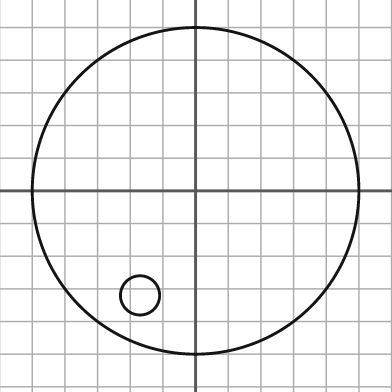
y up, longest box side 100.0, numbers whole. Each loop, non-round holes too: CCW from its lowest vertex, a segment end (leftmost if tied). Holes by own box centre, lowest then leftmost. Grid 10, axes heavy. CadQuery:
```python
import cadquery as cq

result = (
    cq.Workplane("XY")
    .moveTo(0.0, 0.0)
    .circle(50.0)
    .moveTo(-17.0, -32.0)
    .circle(6.0)
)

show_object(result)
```